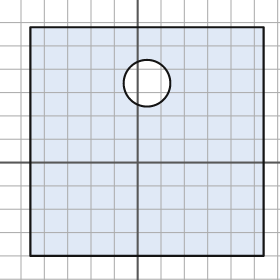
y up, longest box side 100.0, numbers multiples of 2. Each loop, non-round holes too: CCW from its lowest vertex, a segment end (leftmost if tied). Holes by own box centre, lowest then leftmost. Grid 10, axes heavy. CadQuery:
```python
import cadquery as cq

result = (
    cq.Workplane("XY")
    .moveTo(-46.0, -40.0)
    .lineTo(54.0, -40.0)
    .lineTo(54.0, 58.0)
    .lineTo(-46.0, 58.0)
    .close()
    .moveTo(4.0, 34.0)
    .circle(10.0)
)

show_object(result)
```